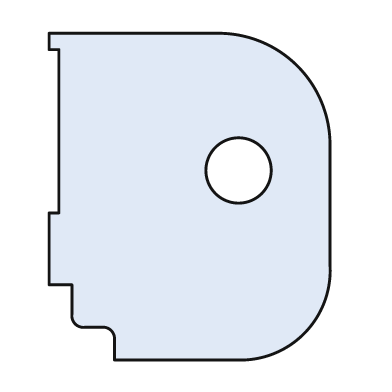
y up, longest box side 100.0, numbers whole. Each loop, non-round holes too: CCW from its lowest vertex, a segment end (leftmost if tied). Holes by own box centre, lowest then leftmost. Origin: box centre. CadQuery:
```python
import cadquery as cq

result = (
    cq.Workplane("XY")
    .moveTo(-23.0, -50.0)
    .lineTo(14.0, -50.0)
    .threePointArc((35.0, -42.0), (43.0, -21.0))
    .lineTo(43.0, 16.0)
    .threePointArc((33.0, 40.0), (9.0, 50.0))
    .lineTo(-43.0, 50.0)
    .lineTo(-43.0, 45.0)
    .lineTo(-40.0, 45.0)
    .lineTo(-40.0, -5.0)
    .lineTo(-43.0, -5.0)
    .lineTo(-43.0, -27.0)
    .lineTo(-36.0, -27.0)
    .lineTo(-36.0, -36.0)
    .threePointArc((-35.0, -39.0), (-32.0, -40.0))
    .lineTo(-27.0, -40.0)
    .threePointArc((-24.0, -41.0), (-23.0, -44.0))
    .close()
    .moveTo(15.0, 8.0)
    .circle(10.0)
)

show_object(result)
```